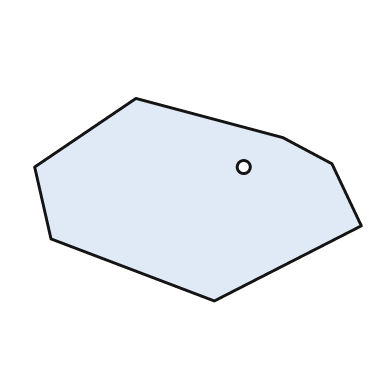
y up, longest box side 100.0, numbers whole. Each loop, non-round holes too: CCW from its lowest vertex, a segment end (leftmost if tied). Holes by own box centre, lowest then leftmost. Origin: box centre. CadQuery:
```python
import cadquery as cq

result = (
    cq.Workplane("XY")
    .moveTo(5.0, -31.0)
    .lineTo(50.0, -8.0)
    .lineTo(41.0, 11.0)
    .lineTo(26.0, 19.0)
    .lineTo(-19.0, 31.0)
    .lineTo(-50.0, 10.0)
    .lineTo(-45.0, -12.0)
    .close()
    .moveTo(14.0, 10.0)
    .circle(2.0)
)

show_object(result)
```